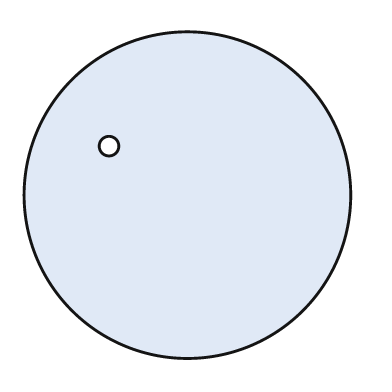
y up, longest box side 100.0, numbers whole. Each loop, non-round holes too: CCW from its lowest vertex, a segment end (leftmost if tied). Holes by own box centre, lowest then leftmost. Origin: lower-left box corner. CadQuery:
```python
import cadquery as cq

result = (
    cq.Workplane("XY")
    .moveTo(50.0, 50.0)
    .circle(50.0)
    .moveTo(26.0, 65.0)
    .circle(3.0)
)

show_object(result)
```